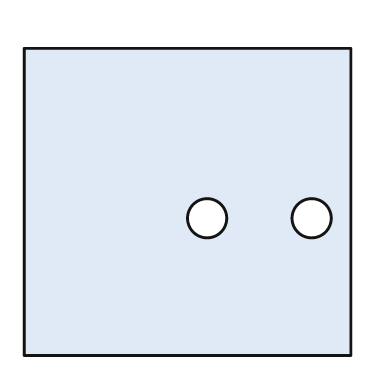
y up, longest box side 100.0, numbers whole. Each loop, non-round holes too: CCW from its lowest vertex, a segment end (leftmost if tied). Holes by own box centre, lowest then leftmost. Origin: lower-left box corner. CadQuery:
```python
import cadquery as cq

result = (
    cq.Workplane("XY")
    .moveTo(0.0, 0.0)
    .lineTo(100.0, 0.0)
    .lineTo(100.0, 94.0)
    .lineTo(0.0, 94.0)
    .close()
    .moveTo(56.0, 42.0)
    .circle(6.0)
    .moveTo(88.0, 42.0)
    .circle(6.0)
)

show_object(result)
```